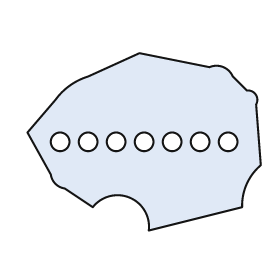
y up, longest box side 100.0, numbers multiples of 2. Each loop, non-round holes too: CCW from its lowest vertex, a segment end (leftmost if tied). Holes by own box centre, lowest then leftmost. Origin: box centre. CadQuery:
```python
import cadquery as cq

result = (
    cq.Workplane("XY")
    .moveTo(2.0, -38.0)
    .lineTo(42.0, -28.0)
    .threePointArc((44.0, -18.0), (50.0, -10.0))
    .lineTo(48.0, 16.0)
    .threePointArc((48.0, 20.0), (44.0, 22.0))
    .lineTo(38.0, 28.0)
    .threePointArc((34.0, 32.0), (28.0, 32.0))
    .lineTo(-2.0, 38.0)
    .lineTo(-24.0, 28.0)
    .threePointArc((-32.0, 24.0), (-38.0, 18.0))
    .lineTo(-50.0, 4.0)
    .lineTo(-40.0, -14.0)
    .threePointArc((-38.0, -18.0), (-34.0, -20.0))
    .lineTo(-22.0, -28.0)
    .threePointArc((-6.0, -24.0), (2.0, -38.0))
    .close()
    .moveTo(-36.0, 0.0)
    .circle(4.0)
    .moveTo(-24.0, 0.0)
    .circle(4.0)
    .moveTo(-12.0, 0.0)
    .circle(4.0)
    .moveTo(0.0, 0.0)
    .circle(4.0)
    .moveTo(12.0, 0.0)
    .circle(4.0)
    .moveTo(24.0, 0.0)
    .circle(4.0)
    .moveTo(36.0, 0.0)
    .circle(4.0)
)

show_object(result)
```